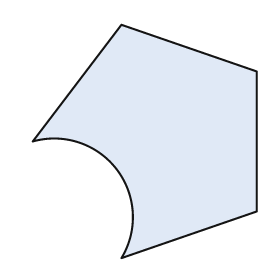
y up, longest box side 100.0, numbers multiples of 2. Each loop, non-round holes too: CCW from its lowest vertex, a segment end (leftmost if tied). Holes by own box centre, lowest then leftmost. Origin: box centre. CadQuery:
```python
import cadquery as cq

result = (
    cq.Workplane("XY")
    .moveTo(-10.0, -50.0)
    .lineTo(48.0, -30.0)
    .lineTo(48.0, 30.0)
    .lineTo(-10.0, 50.0)
    .lineTo(-48.0, 0.0)
    .threePointArc((-12.0, -12.0), (-10.0, -50.0))
    .close()
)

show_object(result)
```